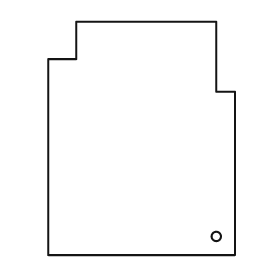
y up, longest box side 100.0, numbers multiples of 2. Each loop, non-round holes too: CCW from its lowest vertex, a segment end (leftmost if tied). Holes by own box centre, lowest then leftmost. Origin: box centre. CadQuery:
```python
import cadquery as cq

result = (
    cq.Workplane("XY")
    .moveTo(-40.0, -50.0)
    .lineTo(40.0, -50.0)
    .lineTo(40.0, 20.0)
    .lineTo(32.0, 20.0)
    .lineTo(32.0, 50.0)
    .lineTo(-28.0, 50.0)
    .lineTo(-28.0, 34.0)
    .lineTo(-40.0, 34.0)
    .close()
    .moveTo(32.0, -42.0)
    .circle(2.0)
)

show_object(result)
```